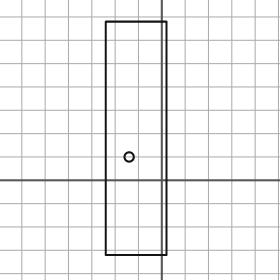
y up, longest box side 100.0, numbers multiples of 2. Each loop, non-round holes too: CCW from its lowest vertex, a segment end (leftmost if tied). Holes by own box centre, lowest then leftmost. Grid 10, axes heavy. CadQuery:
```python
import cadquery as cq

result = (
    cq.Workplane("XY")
    .moveTo(-24.0, -32.0)
    .lineTo(2.0, -32.0)
    .lineTo(2.0, 68.0)
    .lineTo(-24.0, 68.0)
    .close()
    .moveTo(-14.0, 10.0)
    .circle(2.0)
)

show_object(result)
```